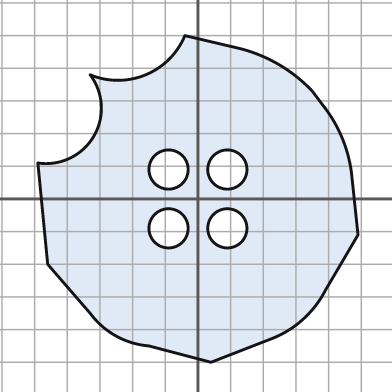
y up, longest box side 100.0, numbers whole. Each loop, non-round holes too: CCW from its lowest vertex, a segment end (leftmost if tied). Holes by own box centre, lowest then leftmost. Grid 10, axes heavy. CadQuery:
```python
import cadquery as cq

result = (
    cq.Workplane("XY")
    .moveTo(4.0, -50.0)
    .lineTo(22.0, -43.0)
    .threePointArc((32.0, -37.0), (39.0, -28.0))
    .lineTo(49.0, -11.0)
    .lineTo(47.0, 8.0)
    .threePointArc((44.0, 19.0), (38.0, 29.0))
    .lineTo(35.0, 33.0)
    .threePointArc((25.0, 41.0), (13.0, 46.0))
    .lineTo(-4.0, 50.0)
    .threePointArc((-16.0, 38.0), (-33.0, 38.0))
    .threePointArc((-32.0, 19.0), (-49.0, 11.0))
    .lineTo(-46.0, -20.0)
    .lineTo(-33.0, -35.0)
    .threePointArc((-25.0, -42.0), (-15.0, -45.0))
    .close()
    .moveTo(-9.0, -9.0)
    .circle(6.0)
    .moveTo(9.0, -9.0)
    .circle(6.0)
    .moveTo(-9.0, 9.0)
    .circle(6.0)
    .moveTo(9.0, 9.0)
    .circle(6.0)
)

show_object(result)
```